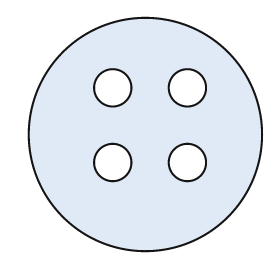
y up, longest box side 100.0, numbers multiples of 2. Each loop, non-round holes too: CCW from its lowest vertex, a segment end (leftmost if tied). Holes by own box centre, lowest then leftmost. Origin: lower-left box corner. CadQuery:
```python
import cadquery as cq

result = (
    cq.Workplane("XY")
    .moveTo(50.0, 50.0)
    .circle(50.0)
    .moveTo(36.0, 38.0)
    .circle(8.0)
    .moveTo(68.0, 38.0)
    .circle(8.0)
    .moveTo(36.0, 70.0)
    .circle(8.0)
    .moveTo(68.0, 70.0)
    .circle(8.0)
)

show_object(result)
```